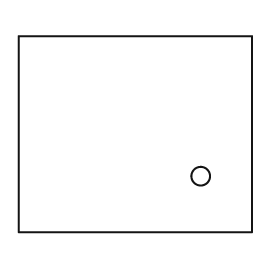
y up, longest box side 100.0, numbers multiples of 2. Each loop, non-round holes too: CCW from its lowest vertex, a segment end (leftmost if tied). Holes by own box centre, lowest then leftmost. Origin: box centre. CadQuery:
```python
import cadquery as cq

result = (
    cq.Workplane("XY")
    .moveTo(-50.0, -42.0)
    .lineTo(50.0, -42.0)
    .lineTo(50.0, 42.0)
    .lineTo(-50.0, 42.0)
    .close()
    .moveTo(28.0, -18.0)
    .circle(4.0)
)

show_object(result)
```